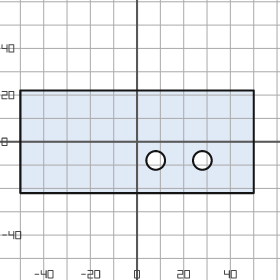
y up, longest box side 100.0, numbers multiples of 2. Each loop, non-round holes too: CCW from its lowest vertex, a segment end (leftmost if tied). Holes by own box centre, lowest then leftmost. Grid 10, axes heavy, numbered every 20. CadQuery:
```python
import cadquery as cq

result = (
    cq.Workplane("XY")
    .moveTo(-50.0, -22.0)
    .lineTo(50.0, -22.0)
    .lineTo(50.0, 22.0)
    .lineTo(-50.0, 22.0)
    .close()
    .moveTo(8.0, -8.0)
    .circle(4.0)
    .moveTo(28.0, -8.0)
    .circle(4.0)
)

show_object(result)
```